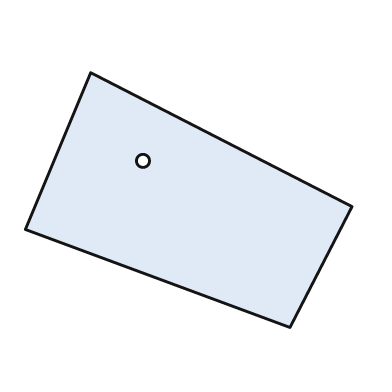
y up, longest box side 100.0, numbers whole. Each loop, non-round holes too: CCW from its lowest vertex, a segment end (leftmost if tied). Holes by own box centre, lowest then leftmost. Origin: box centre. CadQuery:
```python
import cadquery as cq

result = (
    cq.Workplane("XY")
    .moveTo(31.0, -39.0)
    .lineTo(50.0, -2.0)
    .lineTo(-30.0, 39.0)
    .lineTo(-50.0, -9.0)
    .close()
    .moveTo(-14.0, 12.0)
    .circle(2.0)
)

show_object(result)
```